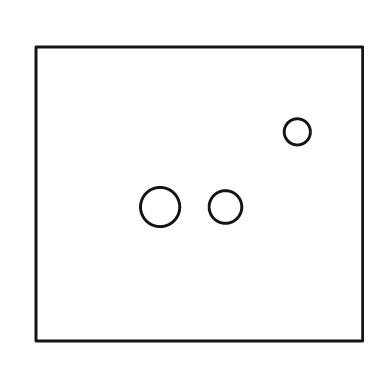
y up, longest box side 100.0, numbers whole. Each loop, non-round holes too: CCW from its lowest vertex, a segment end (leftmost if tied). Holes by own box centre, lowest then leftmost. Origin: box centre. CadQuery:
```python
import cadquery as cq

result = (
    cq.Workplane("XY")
    .moveTo(-50.0, -45.0)
    .lineTo(50.0, -45.0)
    .lineTo(50.0, 45.0)
    .lineTo(-50.0, 45.0)
    .close()
    .moveTo(-12.0, -4.0)
    .circle(6.0)
    .moveTo(8.0, -4.0)
    .circle(5.0)
    .moveTo(30.0, 19.0)
    .circle(4.0)
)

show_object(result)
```